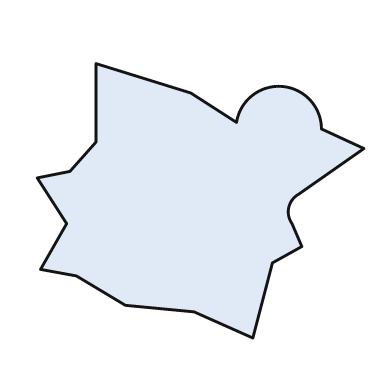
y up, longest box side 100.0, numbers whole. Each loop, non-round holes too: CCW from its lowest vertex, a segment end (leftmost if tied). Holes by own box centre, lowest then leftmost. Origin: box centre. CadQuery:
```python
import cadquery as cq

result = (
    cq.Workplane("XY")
    .moveTo(16.0, -42.0)
    .lineTo(22.0, -19.0)
    .lineTo(31.0, -14.0)
    .lineTo(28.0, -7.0)
    .threePointArc((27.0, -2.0), (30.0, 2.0))
    .lineTo(50.0, 16.0)
    .lineTo(37.0, 22.0)
    .threePointArc((25.0, 35.0), (11.0, 24.0))
    .lineTo(-3.0, 33.0)
    .lineTo(-32.0, 42.0)
    .lineTo(-32.0, 18.0)
    .lineTo(-40.0, 9.0)
    .lineTo(-50.0, 7.0)
    .lineTo(-41.0, -7.0)
    .lineTo(-49.0, -21.0)
    .lineTo(-38.0, -23.0)
    .lineTo(-23.0, -32.0)
    .lineTo(-2.0, -34.0)
    .close()
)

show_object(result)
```